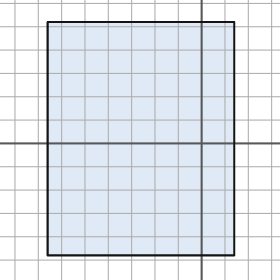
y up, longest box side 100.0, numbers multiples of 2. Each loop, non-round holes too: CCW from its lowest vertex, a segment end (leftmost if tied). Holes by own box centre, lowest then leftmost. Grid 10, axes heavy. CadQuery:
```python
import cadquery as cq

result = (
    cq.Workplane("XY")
    .moveTo(-66.0, -48.0)
    .lineTo(14.0, -48.0)
    .lineTo(14.0, 52.0)
    .lineTo(-66.0, 52.0)
    .close()
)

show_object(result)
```